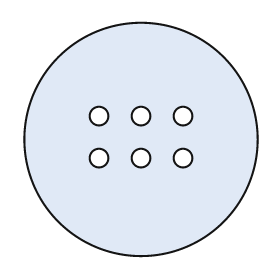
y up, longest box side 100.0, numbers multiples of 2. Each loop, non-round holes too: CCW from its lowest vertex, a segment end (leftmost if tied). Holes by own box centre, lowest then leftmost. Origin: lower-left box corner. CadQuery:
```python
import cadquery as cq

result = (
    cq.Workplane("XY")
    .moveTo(50.0, 50.0)
    .circle(50.0)
    .moveTo(32.0, 42.0)
    .circle(4.0)
    .moveTo(50.0, 42.0)
    .circle(4.0)
    .moveTo(68.0, 42.0)
    .circle(4.0)
    .moveTo(32.0, 60.0)
    .circle(4.0)
    .moveTo(50.0, 60.0)
    .circle(4.0)
    .moveTo(68.0, 60.0)
    .circle(4.0)
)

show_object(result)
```